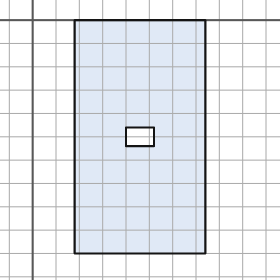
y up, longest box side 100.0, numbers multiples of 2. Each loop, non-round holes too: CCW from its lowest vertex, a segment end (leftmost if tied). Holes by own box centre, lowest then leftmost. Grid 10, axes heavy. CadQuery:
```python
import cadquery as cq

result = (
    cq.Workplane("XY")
    .moveTo(18.0, -100.0)
    .lineTo(74.0, -100.0)
    .lineTo(74.0, 0.0)
    .lineTo(18.0, 0.0)
    .close()
    .moveTo(40.0, -54.0)
    .lineTo(52.0, -54.0)
    .lineTo(52.0, -46.0)
    .lineTo(40.0, -46.0)
    .close()
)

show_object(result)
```